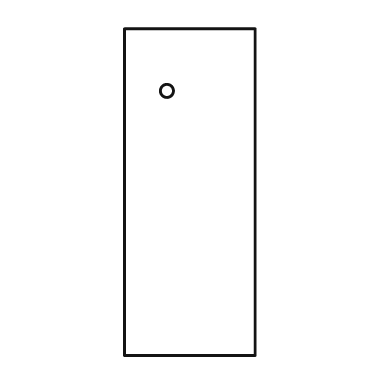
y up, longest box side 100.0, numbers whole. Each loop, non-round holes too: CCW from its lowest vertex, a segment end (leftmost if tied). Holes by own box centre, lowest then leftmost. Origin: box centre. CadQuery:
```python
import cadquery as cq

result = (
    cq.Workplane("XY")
    .moveTo(-20.0, -50.0)
    .lineTo(20.0, -50.0)
    .lineTo(20.0, 50.0)
    .lineTo(-20.0, 50.0)
    .close()
    .moveTo(-7.0, 31.0)
    .circle(2.0)
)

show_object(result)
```